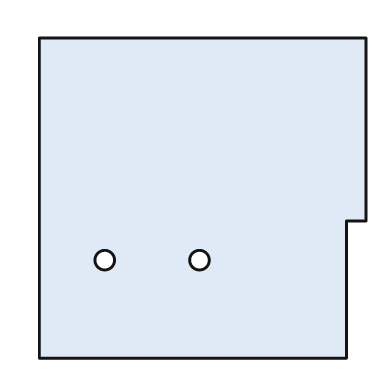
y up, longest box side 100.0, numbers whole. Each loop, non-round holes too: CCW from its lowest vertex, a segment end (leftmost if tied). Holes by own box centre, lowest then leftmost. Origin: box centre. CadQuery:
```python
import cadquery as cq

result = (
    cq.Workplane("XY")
    .moveTo(-50.0, -49.0)
    .lineTo(44.0, -49.0)
    .lineTo(44.0, -7.0)
    .lineTo(50.0, -7.0)
    .lineTo(50.0, 49.0)
    .lineTo(-50.0, 49.0)
    .close()
    .moveTo(-30.0, -19.0)
    .circle(3.0)
    .moveTo(-1.0, -19.0)
    .circle(3.0)
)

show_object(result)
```